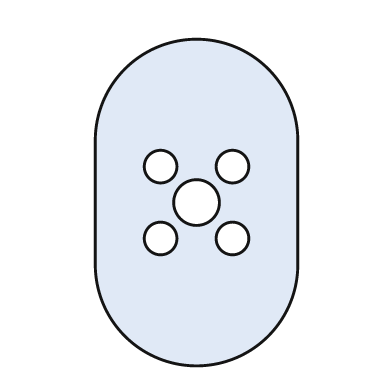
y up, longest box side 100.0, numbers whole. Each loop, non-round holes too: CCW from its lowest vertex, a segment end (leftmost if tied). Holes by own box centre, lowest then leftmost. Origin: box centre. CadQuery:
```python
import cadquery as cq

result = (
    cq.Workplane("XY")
    .moveTo(-31.0, -19.0)
    .threePointArc((0.0, -50.0), (31.0, -19.0))
    .lineTo(31.0, 19.0)
    .threePointArc((0.0, 50.0), (-31.0, 19.0))
    .close()
    .moveTo(-11.0, -11.0)
    .circle(5.0)
    .moveTo(11.0, -11.0)
    .circle(5.0)
    .moveTo(0.0, 0.0)
    .circle(7.0)
    .moveTo(-11.0, 11.0)
    .circle(5.0)
    .moveTo(11.0, 11.0)
    .circle(5.0)
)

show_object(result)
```